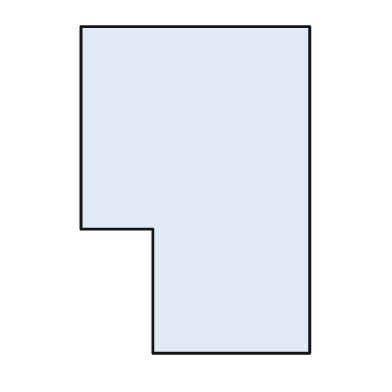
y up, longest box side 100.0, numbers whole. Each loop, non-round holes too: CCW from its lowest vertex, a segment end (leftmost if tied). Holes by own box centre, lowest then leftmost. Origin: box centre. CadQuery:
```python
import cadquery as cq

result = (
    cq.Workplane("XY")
    .moveTo(-13.0, -50.0)
    .lineTo(35.0, -50.0)
    .lineTo(35.0, 50.0)
    .lineTo(-35.0, 50.0)
    .lineTo(-35.0, -12.0)
    .lineTo(-13.0, -12.0)
    .close()
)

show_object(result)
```